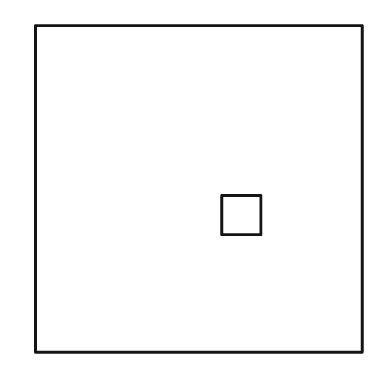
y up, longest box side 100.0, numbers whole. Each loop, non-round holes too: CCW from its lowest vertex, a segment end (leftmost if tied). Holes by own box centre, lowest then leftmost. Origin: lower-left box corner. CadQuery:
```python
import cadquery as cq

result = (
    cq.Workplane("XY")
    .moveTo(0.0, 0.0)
    .lineTo(100.0, 0.0)
    .lineTo(100.0, 100.0)
    .lineTo(0.0, 100.0)
    .close()
    .moveTo(57.0, 36.0)
    .lineTo(69.0, 36.0)
    .lineTo(69.0, 48.0)
    .lineTo(57.0, 48.0)
    .close()
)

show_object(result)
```